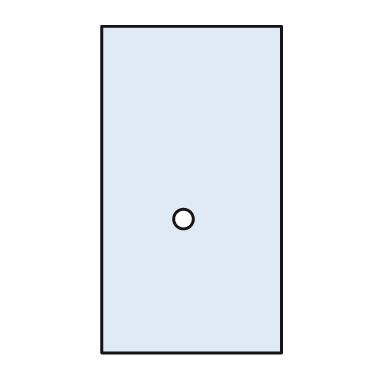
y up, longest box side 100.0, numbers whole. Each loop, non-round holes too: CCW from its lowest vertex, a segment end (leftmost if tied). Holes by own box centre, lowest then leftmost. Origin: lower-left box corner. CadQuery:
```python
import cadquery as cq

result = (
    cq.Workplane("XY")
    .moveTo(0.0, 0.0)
    .lineTo(55.0, 0.0)
    .lineTo(55.0, 100.0)
    .lineTo(0.0, 100.0)
    .close()
    .moveTo(25.0, 41.0)
    .circle(3.0)
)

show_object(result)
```